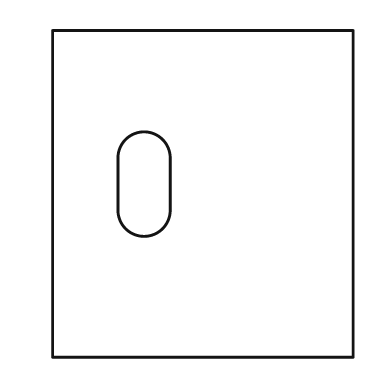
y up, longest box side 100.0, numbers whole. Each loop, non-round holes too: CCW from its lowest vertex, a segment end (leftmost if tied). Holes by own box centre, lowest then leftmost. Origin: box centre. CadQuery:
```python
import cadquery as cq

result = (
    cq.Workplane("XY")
    .moveTo(-46.0, -50.0)
    .lineTo(46.0, -50.0)
    .lineTo(46.0, 50.0)
    .lineTo(-46.0, 50.0)
    .close()
    .moveTo(-26.0, -5.0)
    .threePointArc((-18.0, -13.0), (-10.0, -5.0))
    .lineTo(-10.0, 11.0)
    .threePointArc((-18.0, 19.0), (-26.0, 11.0))
    .close()
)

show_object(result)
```